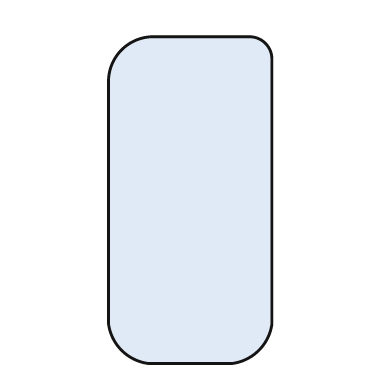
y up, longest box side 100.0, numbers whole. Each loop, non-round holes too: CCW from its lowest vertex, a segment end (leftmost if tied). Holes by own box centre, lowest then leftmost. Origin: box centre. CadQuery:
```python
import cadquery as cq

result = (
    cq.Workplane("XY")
    .moveTo(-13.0, -50.0)
    .lineTo(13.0, -50.0)
    .threePointArc((21.0, -46.0), (25.0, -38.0))
    .lineTo(25.0, 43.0)
    .threePointArc((23.0, 48.0), (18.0, 50.0))
    .lineTo(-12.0, 50.0)
    .threePointArc((-21.0, 46.0), (-25.0, 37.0))
    .lineTo(-25.0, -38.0)
    .threePointArc((-21.0, -46.0), (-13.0, -50.0))
    .close()
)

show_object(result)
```